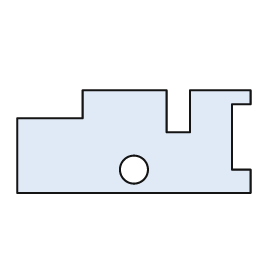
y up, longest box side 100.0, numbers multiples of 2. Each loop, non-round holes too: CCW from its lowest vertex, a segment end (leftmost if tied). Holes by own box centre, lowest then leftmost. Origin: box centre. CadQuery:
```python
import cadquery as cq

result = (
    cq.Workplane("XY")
    .moveTo(-50.0, -22.0)
    .lineTo(50.0, -22.0)
    .lineTo(50.0, -12.0)
    .lineTo(42.0, -12.0)
    .lineTo(42.0, 16.0)
    .lineTo(50.0, 16.0)
    .lineTo(50.0, 22.0)
    .lineTo(24.0, 22.0)
    .lineTo(24.0, 4.0)
    .lineTo(14.0, 4.0)
    .lineTo(14.0, 22.0)
    .lineTo(-22.0, 22.0)
    .lineTo(-22.0, 10.0)
    .lineTo(-50.0, 10.0)
    .close()
    .moveTo(0.0, -12.0)
    .circle(6.0)
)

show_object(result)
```